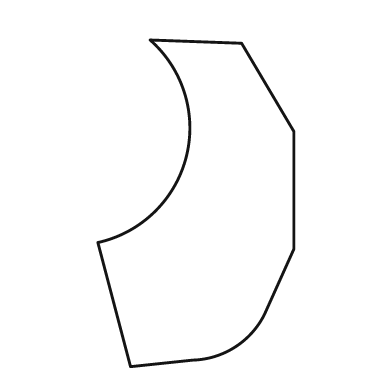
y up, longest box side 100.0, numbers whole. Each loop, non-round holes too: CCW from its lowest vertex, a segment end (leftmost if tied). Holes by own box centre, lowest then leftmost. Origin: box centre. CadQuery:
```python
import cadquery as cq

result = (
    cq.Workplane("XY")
    .moveTo(-20.0, -50.0)
    .lineTo(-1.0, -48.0)
    .threePointArc((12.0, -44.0), (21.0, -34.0))
    .lineTo(30.0, -14.0)
    .lineTo(30.0, 22.0)
    .lineTo(14.0, 49.0)
    .lineTo(-14.0, 50.0)
    .threePointArc((-3.0, 14.0), (-30.0, -12.0))
    .close()
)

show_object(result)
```